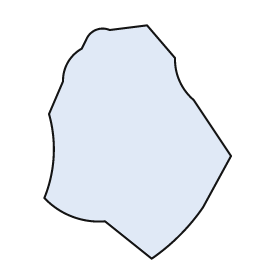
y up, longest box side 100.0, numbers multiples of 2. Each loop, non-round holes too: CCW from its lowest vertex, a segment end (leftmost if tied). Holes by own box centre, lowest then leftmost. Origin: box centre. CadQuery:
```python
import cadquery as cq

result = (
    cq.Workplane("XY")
    .moveTo(6.0, -50.0)
    .threePointArc((18.0, -40.0), (28.0, -28.0))
    .lineTo(40.0, -6.0)
    .lineTo(24.0, 18.0)
    .threePointArc((18.0, 26.0), (16.0, 36.0))
    .lineTo(4.0, 50.0)
    .lineTo(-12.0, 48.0)
    .threePointArc((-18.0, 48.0), (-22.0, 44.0))
    .lineTo(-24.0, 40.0)
    .threePointArc((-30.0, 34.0), (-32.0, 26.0))
    .lineTo(-38.0, 12.0)
    .threePointArc((-36.0, -6.0), (-40.0, -24.0))
    .threePointArc((-28.0, -32.0), (-14.0, -34.0))
    .close()
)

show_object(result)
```